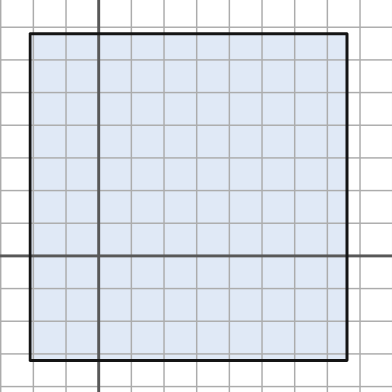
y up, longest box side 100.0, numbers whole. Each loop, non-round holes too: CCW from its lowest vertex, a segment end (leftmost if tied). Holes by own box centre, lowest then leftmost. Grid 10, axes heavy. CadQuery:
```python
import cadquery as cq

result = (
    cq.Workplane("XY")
    .moveTo(-21.0, -32.0)
    .lineTo(76.0, -32.0)
    .lineTo(76.0, 68.0)
    .lineTo(-21.0, 68.0)
    .close()
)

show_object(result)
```